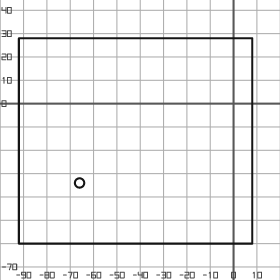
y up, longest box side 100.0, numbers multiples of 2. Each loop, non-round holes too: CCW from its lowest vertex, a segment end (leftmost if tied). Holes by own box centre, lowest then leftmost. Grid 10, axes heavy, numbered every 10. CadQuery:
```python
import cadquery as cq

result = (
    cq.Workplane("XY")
    .moveTo(-92.0, -60.0)
    .lineTo(8.0, -60.0)
    .lineTo(8.0, 28.0)
    .lineTo(-92.0, 28.0)
    .close()
    .moveTo(-66.0, -34.0)
    .circle(2.0)
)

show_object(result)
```